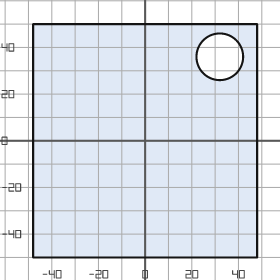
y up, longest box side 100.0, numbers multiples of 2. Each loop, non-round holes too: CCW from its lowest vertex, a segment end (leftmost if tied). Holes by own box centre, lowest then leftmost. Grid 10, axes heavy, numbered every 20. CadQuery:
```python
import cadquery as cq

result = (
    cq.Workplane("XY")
    .moveTo(-48.0, -50.0)
    .lineTo(48.0, -50.0)
    .lineTo(48.0, 50.0)
    .lineTo(-48.0, 50.0)
    .close()
    .moveTo(32.0, 36.0)
    .circle(10.0)
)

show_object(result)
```